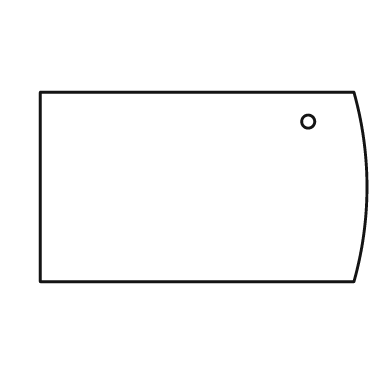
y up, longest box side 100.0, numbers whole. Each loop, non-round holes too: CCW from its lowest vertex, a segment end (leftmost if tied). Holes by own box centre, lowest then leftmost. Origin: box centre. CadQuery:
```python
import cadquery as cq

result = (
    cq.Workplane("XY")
    .moveTo(-50.0, -29.0)
    .lineTo(46.0, -29.0)
    .threePointArc((50.0, 0.0), (46.0, 29.0))
    .lineTo(-50.0, 29.0)
    .close()
    .moveTo(32.0, 20.0)
    .circle(2.0)
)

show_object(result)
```